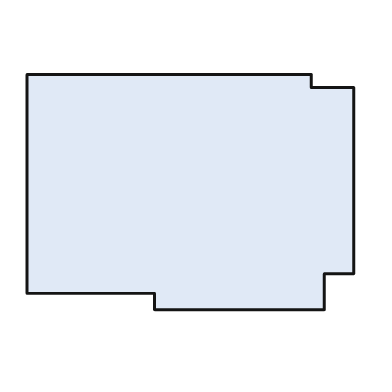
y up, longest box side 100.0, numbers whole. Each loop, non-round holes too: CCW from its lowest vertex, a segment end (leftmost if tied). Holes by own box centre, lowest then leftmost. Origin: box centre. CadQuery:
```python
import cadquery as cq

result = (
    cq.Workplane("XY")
    .moveTo(-11.0, -36.0)
    .lineTo(41.0, -36.0)
    .lineTo(41.0, -25.0)
    .lineTo(50.0, -25.0)
    .lineTo(50.0, 32.0)
    .lineTo(37.0, 32.0)
    .lineTo(37.0, 36.0)
    .lineTo(-50.0, 36.0)
    .lineTo(-50.0, -31.0)
    .lineTo(-11.0, -31.0)
    .close()
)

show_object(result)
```